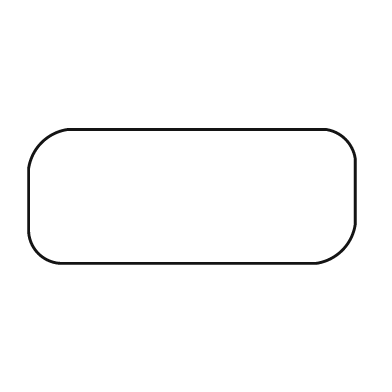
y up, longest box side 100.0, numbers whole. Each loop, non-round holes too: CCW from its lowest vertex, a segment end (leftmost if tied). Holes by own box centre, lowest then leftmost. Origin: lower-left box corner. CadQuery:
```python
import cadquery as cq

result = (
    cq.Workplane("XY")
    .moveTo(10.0, 0.0)
    .lineTo(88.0, 0.0)
    .threePointArc((96.0, 4.0), (100.0, 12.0))
    .lineTo(100.0, 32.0)
    .threePointArc((97.0, 38.0), (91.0, 41.0))
    .lineTo(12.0, 41.0)
    .threePointArc((4.0, 37.0), (0.0, 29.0))
    .lineTo(0.0, 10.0)
    .threePointArc((3.0, 3.0), (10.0, 0.0))
    .close()
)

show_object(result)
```